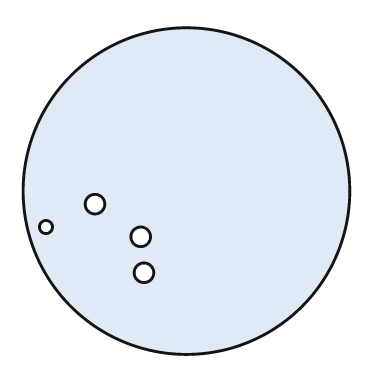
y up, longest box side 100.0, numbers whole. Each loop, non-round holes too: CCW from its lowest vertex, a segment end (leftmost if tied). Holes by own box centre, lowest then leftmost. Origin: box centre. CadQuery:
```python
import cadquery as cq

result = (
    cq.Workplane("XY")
    .moveTo(0.0, 0.0)
    .circle(50.0)
    .moveTo(-13.0, -25.0)
    .circle(3.0)
    .moveTo(-14.0, -14.0)
    .circle(3.0)
    .moveTo(-43.0, -11.0)
    .circle(2.0)
    .moveTo(-28.0, -4.0)
    .circle(3.0)
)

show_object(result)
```